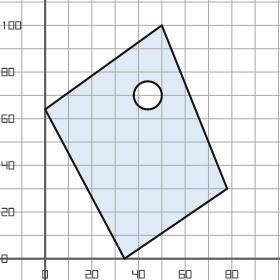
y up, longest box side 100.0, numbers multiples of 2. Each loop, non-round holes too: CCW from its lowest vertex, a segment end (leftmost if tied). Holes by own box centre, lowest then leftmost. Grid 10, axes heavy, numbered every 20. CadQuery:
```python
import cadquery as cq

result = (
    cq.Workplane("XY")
    .moveTo(34.0, 0.0)
    .lineTo(78.0, 30.0)
    .lineTo(50.0, 100.0)
    .lineTo(0.0, 64.0)
    .close()
    .moveTo(44.0, 70.0)
    .circle(6.0)
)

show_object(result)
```